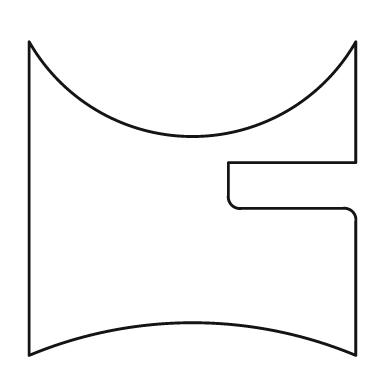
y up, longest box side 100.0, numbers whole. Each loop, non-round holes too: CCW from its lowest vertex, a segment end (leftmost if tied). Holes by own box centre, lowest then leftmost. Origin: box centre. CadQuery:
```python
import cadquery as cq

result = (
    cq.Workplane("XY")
    .moveTo(-50.0, -48.0)
    .threePointArc((0.0, -38.0), (50.0, -48.0))
    .lineTo(50.0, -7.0)
    .threePointArc((49.0, -4.0), (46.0, -3.0))
    .lineTo(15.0, -3.0)
    .threePointArc((12.0, -2.0), (11.0, 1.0))
    .lineTo(11.0, 11.0)
    .lineTo(50.0, 11.0)
    .lineTo(50.0, 48.0)
    .threePointArc((0.0, 19.0), (-50.0, 48.0))
    .close()
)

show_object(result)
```